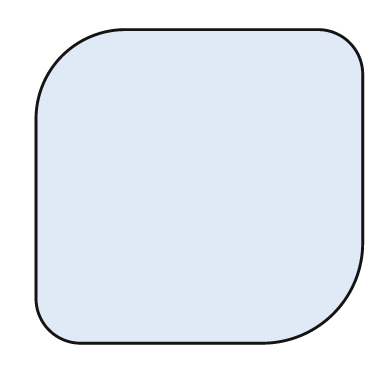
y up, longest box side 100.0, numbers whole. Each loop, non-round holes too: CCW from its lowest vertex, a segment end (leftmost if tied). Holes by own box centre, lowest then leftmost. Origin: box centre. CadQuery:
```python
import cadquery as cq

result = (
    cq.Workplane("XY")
    .moveTo(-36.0, -48.0)
    .lineTo(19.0, -48.0)
    .threePointArc((41.0, -39.0), (50.0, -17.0))
    .lineTo(50.0, 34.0)
    .threePointArc((46.0, 44.0), (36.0, 48.0))
    .lineTo(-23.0, 48.0)
    .threePointArc((-42.0, 40.0), (-50.0, 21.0))
    .lineTo(-50.0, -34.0)
    .threePointArc((-46.0, -44.0), (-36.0, -48.0))
    .close()
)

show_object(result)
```